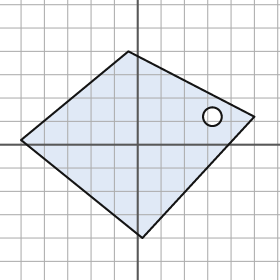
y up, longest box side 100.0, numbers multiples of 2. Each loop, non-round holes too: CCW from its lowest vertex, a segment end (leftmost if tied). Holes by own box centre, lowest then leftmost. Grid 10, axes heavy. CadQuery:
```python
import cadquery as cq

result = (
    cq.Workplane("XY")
    .moveTo(2.0, -40.0)
    .lineTo(50.0, 12.0)
    .lineTo(-4.0, 40.0)
    .lineTo(-50.0, 2.0)
    .close()
    .moveTo(32.0, 12.0)
    .circle(4.0)
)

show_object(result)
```